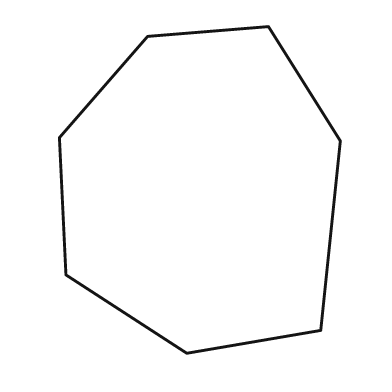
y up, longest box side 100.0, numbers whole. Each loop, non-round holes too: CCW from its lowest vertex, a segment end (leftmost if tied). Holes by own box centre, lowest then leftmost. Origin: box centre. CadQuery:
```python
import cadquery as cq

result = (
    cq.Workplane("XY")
    .moveTo(-4.0, -50.0)
    .lineTo(37.0, -43.0)
    .lineTo(43.0, 15.0)
    .lineTo(21.0, 50.0)
    .lineTo(-16.0, 47.0)
    .lineTo(-43.0, 16.0)
    .lineTo(-41.0, -26.0)
    .close()
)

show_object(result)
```